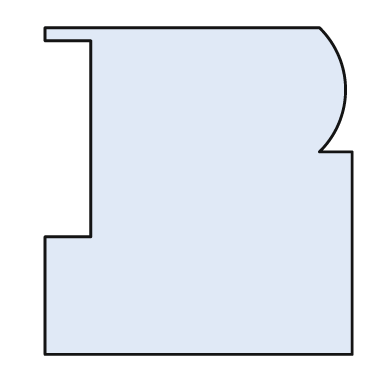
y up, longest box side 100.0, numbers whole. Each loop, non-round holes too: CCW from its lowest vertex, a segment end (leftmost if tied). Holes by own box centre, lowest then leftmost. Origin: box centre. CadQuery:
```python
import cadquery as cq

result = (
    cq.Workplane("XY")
    .moveTo(-47.0, -50.0)
    .lineTo(47.0, -50.0)
    .lineTo(47.0, 12.0)
    .lineTo(37.0, 12.0)
    .threePointArc((45.0, 31.0), (37.0, 50.0))
    .lineTo(-47.0, 50.0)
    .lineTo(-47.0, 46.0)
    .lineTo(-33.0, 46.0)
    .lineTo(-33.0, -14.0)
    .lineTo(-47.0, -14.0)
    .close()
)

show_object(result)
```